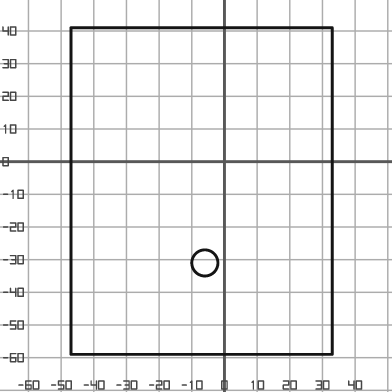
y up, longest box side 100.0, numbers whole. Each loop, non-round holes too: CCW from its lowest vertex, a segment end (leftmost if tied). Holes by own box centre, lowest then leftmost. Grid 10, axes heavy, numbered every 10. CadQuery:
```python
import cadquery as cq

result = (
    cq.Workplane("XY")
    .moveTo(-47.0, -59.0)
    .lineTo(33.0, -59.0)
    .lineTo(33.0, 41.0)
    .lineTo(-47.0, 41.0)
    .close()
    .moveTo(-6.0, -31.0)
    .circle(4.0)
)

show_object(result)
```